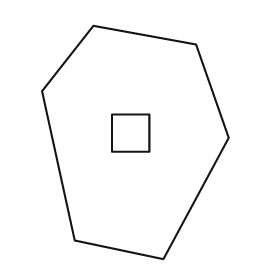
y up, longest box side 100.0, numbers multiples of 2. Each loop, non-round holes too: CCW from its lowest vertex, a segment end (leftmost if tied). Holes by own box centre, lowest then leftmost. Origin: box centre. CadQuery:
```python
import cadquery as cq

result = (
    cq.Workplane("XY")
    .moveTo(12.0, -50.0)
    .lineTo(40.0, 2.0)
    .lineTo(26.0, 42.0)
    .lineTo(-18.0, 50.0)
    .lineTo(-40.0, 22.0)
    .lineTo(-26.0, -42.0)
    .close()
    .moveTo(-10.0, -4.0)
    .lineTo(6.0, -4.0)
    .lineTo(6.0, 12.0)
    .lineTo(-10.0, 12.0)
    .close()
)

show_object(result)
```